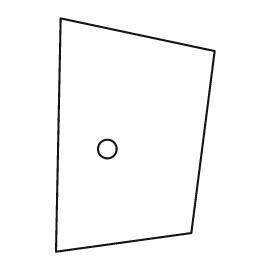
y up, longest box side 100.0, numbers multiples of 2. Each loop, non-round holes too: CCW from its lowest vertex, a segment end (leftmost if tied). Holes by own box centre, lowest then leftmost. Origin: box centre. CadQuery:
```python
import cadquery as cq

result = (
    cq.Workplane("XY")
    .moveTo(-34.0, -50.0)
    .lineTo(24.0, -42.0)
    .lineTo(34.0, 36.0)
    .lineTo(-32.0, 50.0)
    .close()
    .moveTo(-12.0, -6.0)
    .circle(4.0)
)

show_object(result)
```